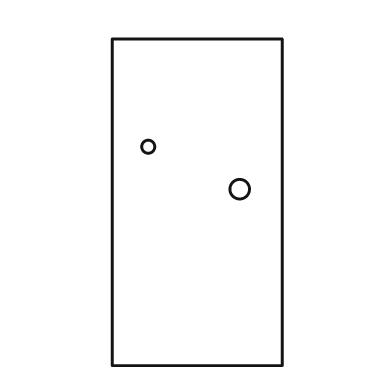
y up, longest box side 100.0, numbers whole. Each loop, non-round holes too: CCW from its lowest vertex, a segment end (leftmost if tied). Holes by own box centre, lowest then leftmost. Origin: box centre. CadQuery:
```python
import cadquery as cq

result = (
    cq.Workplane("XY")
    .moveTo(-26.0, -50.0)
    .lineTo(26.0, -50.0)
    .lineTo(26.0, 50.0)
    .lineTo(-26.0, 50.0)
    .close()
    .moveTo(13.0, 4.0)
    .circle(3.0)
    .moveTo(-15.0, 17.0)
    .circle(2.0)
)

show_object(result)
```